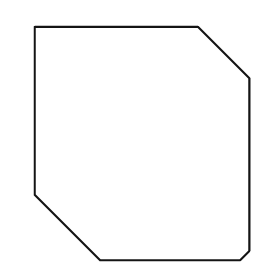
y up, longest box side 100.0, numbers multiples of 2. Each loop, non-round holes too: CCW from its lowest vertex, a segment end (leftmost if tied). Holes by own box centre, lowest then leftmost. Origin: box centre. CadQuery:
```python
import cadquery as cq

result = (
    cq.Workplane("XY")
    .moveTo(-18.0, -50.0)
    .lineTo(42.0, -50.0)
    .lineTo(46.0, -46.0)
    .lineTo(46.0, 28.0)
    .lineTo(24.0, 50.0)
    .lineTo(-46.0, 50.0)
    .lineTo(-46.0, -22.0)
    .close()
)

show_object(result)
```